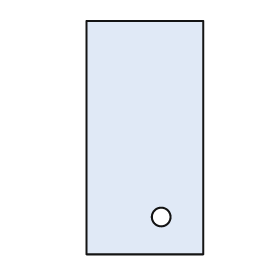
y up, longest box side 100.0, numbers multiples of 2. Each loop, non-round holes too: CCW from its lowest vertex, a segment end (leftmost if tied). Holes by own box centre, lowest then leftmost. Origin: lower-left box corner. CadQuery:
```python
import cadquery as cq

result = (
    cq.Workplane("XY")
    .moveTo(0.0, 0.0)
    .lineTo(50.0, 0.0)
    .lineTo(50.0, 100.0)
    .lineTo(0.0, 100.0)
    .close()
    .moveTo(32.0, 16.0)
    .circle(4.0)
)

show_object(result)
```